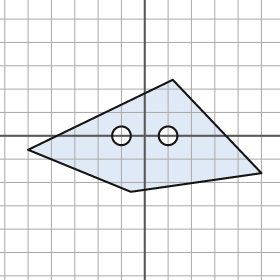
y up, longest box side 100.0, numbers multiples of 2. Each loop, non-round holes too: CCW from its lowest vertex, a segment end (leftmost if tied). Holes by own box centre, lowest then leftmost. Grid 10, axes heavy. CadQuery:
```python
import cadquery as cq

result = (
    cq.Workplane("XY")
    .moveTo(-6.0, -24.0)
    .lineTo(50.0, -16.0)
    .lineTo(12.0, 24.0)
    .lineTo(-50.0, -6.0)
    .close()
    .moveTo(-10.0, 0.0)
    .circle(4.0)
    .moveTo(10.0, 0.0)
    .circle(4.0)
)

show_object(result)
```